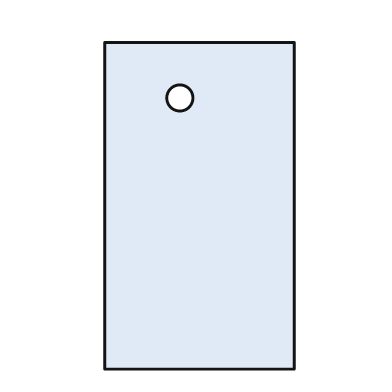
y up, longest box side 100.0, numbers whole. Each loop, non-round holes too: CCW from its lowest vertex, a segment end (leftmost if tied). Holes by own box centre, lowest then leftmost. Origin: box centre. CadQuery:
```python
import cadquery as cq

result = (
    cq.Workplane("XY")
    .moveTo(-29.0, -50.0)
    .lineTo(29.0, -50.0)
    .lineTo(29.0, 50.0)
    .lineTo(-29.0, 50.0)
    .close()
    .moveTo(-6.0, 33.0)
    .circle(4.0)
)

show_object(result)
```